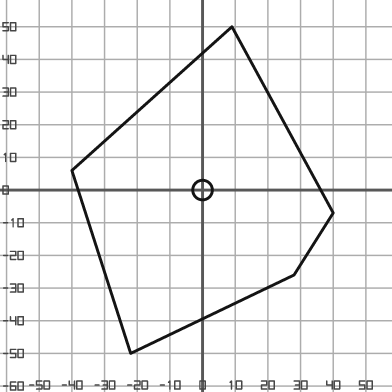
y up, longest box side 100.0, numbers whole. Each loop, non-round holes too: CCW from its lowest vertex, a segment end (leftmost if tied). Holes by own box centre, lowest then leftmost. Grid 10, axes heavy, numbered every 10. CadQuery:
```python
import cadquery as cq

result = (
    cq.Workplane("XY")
    .moveTo(-22.0, -50.0)
    .lineTo(28.0, -26.0)
    .lineTo(40.0, -7.0)
    .lineTo(9.0, 50.0)
    .lineTo(-40.0, 6.0)
    .close()
    .moveTo(0.0, 0.0)
    .circle(3.0)
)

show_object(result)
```